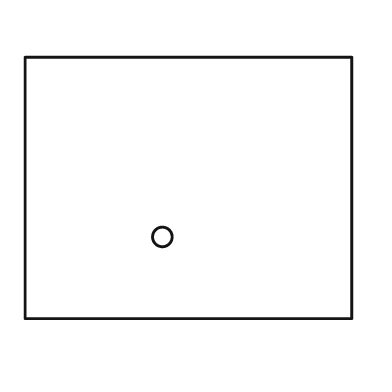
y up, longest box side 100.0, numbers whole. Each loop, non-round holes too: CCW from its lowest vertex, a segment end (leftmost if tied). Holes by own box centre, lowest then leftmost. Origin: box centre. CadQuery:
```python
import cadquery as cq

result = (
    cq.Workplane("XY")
    .moveTo(-50.0, -40.0)
    .lineTo(50.0, -40.0)
    .lineTo(50.0, 40.0)
    .lineTo(-50.0, 40.0)
    .close()
    .moveTo(-8.0, -15.0)
    .circle(3.0)
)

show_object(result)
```